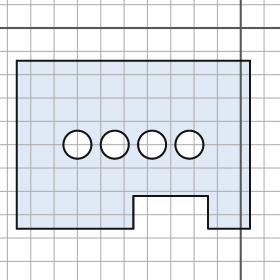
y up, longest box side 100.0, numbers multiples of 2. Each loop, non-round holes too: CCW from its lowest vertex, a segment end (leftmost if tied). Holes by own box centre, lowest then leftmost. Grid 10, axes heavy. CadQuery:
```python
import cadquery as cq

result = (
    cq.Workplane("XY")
    .moveTo(-96.0, -86.0)
    .lineTo(-46.0, -86.0)
    .lineTo(-46.0, -72.0)
    .lineTo(-14.0, -72.0)
    .lineTo(-14.0, -86.0)
    .lineTo(4.0, -86.0)
    .lineTo(4.0, -14.0)
    .lineTo(-96.0, -14.0)
    .close()
    .moveTo(-70.0, -50.0)
    .circle(6.0)
    .moveTo(-54.0, -50.0)
    .circle(6.0)
    .moveTo(-38.0, -50.0)
    .circle(6.0)
    .moveTo(-22.0, -50.0)
    .circle(6.0)
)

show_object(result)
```